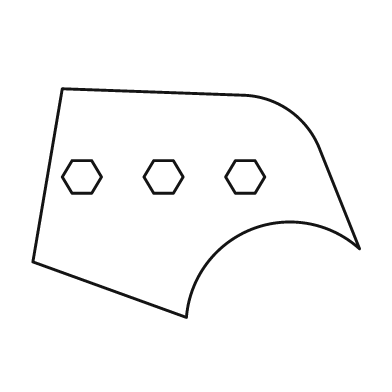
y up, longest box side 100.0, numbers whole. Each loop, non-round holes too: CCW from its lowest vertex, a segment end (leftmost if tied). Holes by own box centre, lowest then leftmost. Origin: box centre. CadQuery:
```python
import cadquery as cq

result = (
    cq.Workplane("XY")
    .moveTo(-3.0, -35.0)
    .threePointArc((17.0, -8.0), (50.0, -14.0))
    .lineTo(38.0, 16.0)
    .threePointArc((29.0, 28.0), (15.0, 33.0))
    .lineTo(-41.0, 35.0)
    .lineTo(-50.0, -18.0)
    .close()
    .moveTo(-38.0, 3.0)
    .lineTo(-32.0, 3.0)
    .lineTo(-29.0, 8.0)
    .lineTo(-32.0, 13.0)
    .lineTo(-38.0, 13.0)
    .lineTo(-41.0, 8.0)
    .close()
    .moveTo(-13.0, 3.0)
    .lineTo(-7.0, 3.0)
    .lineTo(-4.0, 8.0)
    .lineTo(-7.0, 13.0)
    .lineTo(-13.0, 13.0)
    .lineTo(-16.0, 8.0)
    .close()
    .moveTo(12.0, 3.0)
    .lineTo(18.0, 3.0)
    .lineTo(21.0, 8.0)
    .lineTo(18.0, 13.0)
    .lineTo(12.0, 13.0)
    .lineTo(9.0, 8.0)
    .close()
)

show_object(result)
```